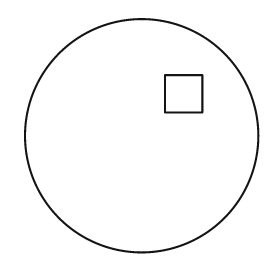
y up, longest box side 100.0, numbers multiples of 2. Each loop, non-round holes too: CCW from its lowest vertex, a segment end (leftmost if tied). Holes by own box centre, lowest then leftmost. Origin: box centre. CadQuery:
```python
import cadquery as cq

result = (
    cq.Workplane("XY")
    .moveTo(0.0, 0.0)
    .circle(50.0)
    .moveTo(10.0, 10.0)
    .lineTo(26.0, 10.0)
    .lineTo(26.0, 26.0)
    .lineTo(10.0, 26.0)
    .close()
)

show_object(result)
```